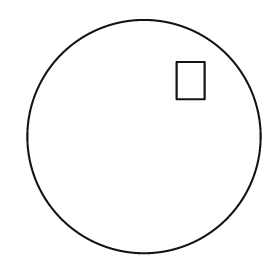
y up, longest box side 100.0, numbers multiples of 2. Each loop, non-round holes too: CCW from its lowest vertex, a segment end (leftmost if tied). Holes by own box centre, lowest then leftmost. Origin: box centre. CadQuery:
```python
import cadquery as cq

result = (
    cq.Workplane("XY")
    .moveTo(0.0, 0.0)
    .circle(50.0)
    .moveTo(14.0, 16.0)
    .lineTo(26.0, 16.0)
    .lineTo(26.0, 32.0)
    .lineTo(14.0, 32.0)
    .close()
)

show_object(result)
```